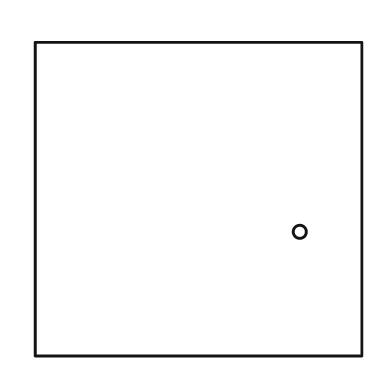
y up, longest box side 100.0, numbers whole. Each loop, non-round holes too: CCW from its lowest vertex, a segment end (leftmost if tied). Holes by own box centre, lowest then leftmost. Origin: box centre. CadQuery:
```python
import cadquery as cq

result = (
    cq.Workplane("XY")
    .moveTo(-50.0, -48.0)
    .lineTo(50.0, -48.0)
    .lineTo(50.0, 48.0)
    .lineTo(-50.0, 48.0)
    .close()
    .moveTo(31.0, -10.0)
    .circle(2.0)
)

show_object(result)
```